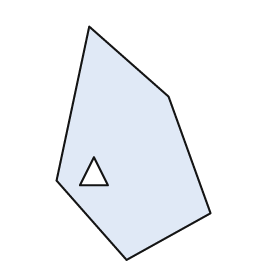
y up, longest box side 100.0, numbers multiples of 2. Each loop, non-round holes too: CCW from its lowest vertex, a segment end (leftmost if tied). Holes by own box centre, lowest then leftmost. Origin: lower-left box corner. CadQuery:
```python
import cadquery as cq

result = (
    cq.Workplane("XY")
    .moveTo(30.0, 0.0)
    .lineTo(66.0, 20.0)
    .lineTo(48.0, 70.0)
    .lineTo(14.0, 100.0)
    .lineTo(0.0, 34.0)
    .close()
    .moveTo(10.0, 32.0)
    .lineTo(22.0, 32.0)
    .lineTo(16.0, 44.0)
    .close()
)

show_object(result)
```